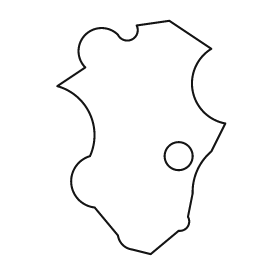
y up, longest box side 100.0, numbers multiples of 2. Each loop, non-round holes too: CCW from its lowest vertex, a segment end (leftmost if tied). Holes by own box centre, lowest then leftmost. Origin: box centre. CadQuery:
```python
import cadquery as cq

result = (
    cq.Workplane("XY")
    .moveTo(4.0, -50.0)
    .lineTo(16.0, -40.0)
    .threePointArc((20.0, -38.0), (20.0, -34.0))
    .lineTo(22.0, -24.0)
    .threePointArc((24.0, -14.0), (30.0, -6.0))
    .lineTo(36.0, 6.0)
    .threePointArc((22.0, 20.0), (30.0, 38.0))
    .lineTo(12.0, 50.0)
    .lineTo(-2.0, 48.0)
    .threePointArc((-4.0, 42.0), (-10.0, 44.0))
    .threePointArc((-24.0, 44.0), (-24.0, 30.0))
    .lineTo(-36.0, 22.0)
    .threePointArc((-22.0, 10.0), (-22.0, -8.0))
    .threePointArc((-30.0, -20.0), (-20.0, -30.0))
    .lineTo(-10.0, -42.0)
    .threePointArc((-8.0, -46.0), (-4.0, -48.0))
    .close()
    .moveTo(16.0, -8.0)
    .circle(6.0)
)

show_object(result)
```